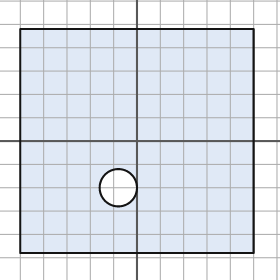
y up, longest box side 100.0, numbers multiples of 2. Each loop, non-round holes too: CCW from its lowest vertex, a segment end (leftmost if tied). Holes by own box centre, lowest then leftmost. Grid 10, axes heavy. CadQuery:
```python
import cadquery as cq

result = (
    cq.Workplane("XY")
    .moveTo(-50.0, -48.0)
    .lineTo(50.0, -48.0)
    .lineTo(50.0, 48.0)
    .lineTo(-50.0, 48.0)
    .close()
    .moveTo(-8.0, -20.0)
    .circle(8.0)
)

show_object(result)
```